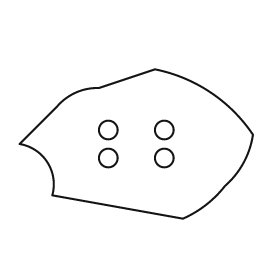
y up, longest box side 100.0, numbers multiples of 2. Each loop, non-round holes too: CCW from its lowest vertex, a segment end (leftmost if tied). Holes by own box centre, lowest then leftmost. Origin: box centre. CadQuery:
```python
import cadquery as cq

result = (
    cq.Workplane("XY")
    .moveTo(20.0, -32.0)
    .threePointArc((30.0, -26.0), (38.0, -18.0))
    .threePointArc((46.0, -8.0), (50.0, 4.0))
    .threePointArc((32.0, 22.0), (8.0, 32.0))
    .lineTo(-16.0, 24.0)
    .threePointArc((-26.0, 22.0), (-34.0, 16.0))
    .lineTo(-50.0, 0.0)
    .threePointArc((-38.0, -8.0), (-36.0, -22.0))
    .close()
    .moveTo(-12.0, -6.0)
    .circle(4.0)
    .moveTo(12.0, -6.0)
    .circle(4.0)
    .moveTo(-12.0, 6.0)
    .circle(4.0)
    .moveTo(12.0, 6.0)
    .circle(4.0)
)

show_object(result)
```